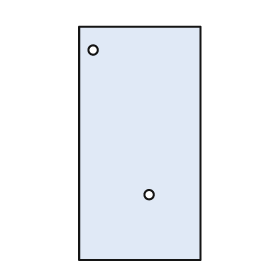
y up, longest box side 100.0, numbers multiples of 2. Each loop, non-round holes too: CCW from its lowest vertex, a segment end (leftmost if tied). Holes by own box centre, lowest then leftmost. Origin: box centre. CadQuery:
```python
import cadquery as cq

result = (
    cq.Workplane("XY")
    .moveTo(-26.0, -50.0)
    .lineTo(26.0, -50.0)
    .lineTo(26.0, 50.0)
    .lineTo(-26.0, 50.0)
    .close()
    .moveTo(4.0, -22.0)
    .circle(2.0)
    .moveTo(-20.0, 40.0)
    .circle(2.0)
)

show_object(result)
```